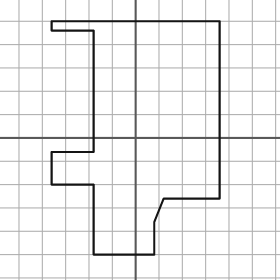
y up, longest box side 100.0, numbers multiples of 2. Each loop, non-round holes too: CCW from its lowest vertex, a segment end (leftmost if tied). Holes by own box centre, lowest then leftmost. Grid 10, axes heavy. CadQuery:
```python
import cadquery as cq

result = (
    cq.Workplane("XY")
    .moveTo(-18.0, -50.0)
    .lineTo(8.0, -50.0)
    .lineTo(8.0, -36.0)
    .lineTo(12.0, -26.0)
    .lineTo(36.0, -26.0)
    .lineTo(36.0, 50.0)
    .lineTo(-36.0, 50.0)
    .lineTo(-36.0, 46.0)
    .lineTo(-18.0, 46.0)
    .lineTo(-18.0, -6.0)
    .lineTo(-36.0, -6.0)
    .lineTo(-36.0, -20.0)
    .lineTo(-18.0, -20.0)
    .close()
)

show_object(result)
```